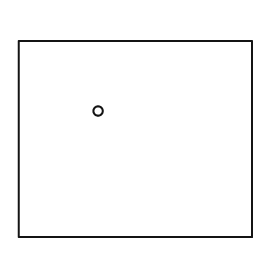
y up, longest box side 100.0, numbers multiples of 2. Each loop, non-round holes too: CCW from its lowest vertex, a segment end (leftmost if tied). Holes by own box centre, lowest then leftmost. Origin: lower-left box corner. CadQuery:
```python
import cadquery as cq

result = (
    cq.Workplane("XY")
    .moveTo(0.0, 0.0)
    .lineTo(100.0, 0.0)
    .lineTo(100.0, 84.0)
    .lineTo(0.0, 84.0)
    .close()
    .moveTo(34.0, 54.0)
    .circle(2.0)
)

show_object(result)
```